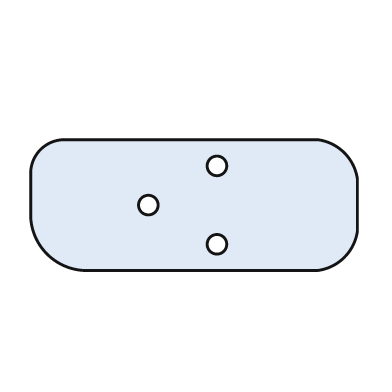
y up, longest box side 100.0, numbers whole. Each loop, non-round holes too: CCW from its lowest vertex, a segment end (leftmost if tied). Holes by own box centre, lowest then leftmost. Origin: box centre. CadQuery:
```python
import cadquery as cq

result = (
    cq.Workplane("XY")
    .moveTo(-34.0, -20.0)
    .lineTo(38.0, -20.0)
    .threePointArc((46.0, -16.0), (50.0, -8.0))
    .lineTo(50.0, 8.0)
    .threePointArc((46.0, 16.0), (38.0, 20.0))
    .lineTo(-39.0, 20.0)
    .threePointArc((-47.0, 17.0), (-50.0, 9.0))
    .lineTo(-50.0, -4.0)
    .threePointArc((-45.0, -15.0), (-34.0, -20.0))
    .close()
    .moveTo(7.0, -12.0)
    .circle(3.0)
    .moveTo(-14.0, 0.0)
    .circle(3.0)
    .moveTo(7.0, 12.0)
    .circle(3.0)
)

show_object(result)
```